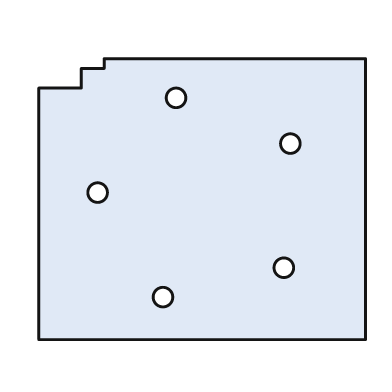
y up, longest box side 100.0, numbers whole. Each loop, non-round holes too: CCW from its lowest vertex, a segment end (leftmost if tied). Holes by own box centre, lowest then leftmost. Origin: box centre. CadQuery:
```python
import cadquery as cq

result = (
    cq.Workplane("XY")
    .moveTo(-50.0, -43.0)
    .lineTo(50.0, -43.0)
    .lineTo(50.0, 43.0)
    .lineTo(-30.0, 43.0)
    .lineTo(-30.0, 40.0)
    .lineTo(-37.0, 40.0)
    .lineTo(-37.0, 34.0)
    .lineTo(-50.0, 34.0)
    .close()
    .moveTo(-12.0, -30.0)
    .circle(3.0)
    .moveTo(25.0, -21.0)
    .circle(3.0)
    .moveTo(-32.0, 2.0)
    .circle(3.0)
    .moveTo(27.0, 17.0)
    .circle(3.0)
    .moveTo(-8.0, 31.0)
    .circle(3.0)
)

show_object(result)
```